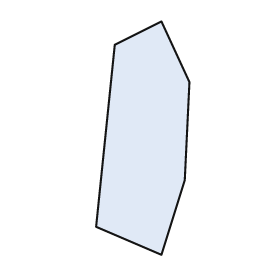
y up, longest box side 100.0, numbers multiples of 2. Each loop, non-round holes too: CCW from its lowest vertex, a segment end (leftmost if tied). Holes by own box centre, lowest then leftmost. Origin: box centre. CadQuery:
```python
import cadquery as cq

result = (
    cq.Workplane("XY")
    .moveTo(8.0, -50.0)
    .lineTo(18.0, -18.0)
    .lineTo(20.0, 24.0)
    .lineTo(8.0, 50.0)
    .lineTo(-12.0, 40.0)
    .lineTo(-20.0, -38.0)
    .close()
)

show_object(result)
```